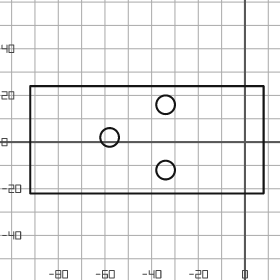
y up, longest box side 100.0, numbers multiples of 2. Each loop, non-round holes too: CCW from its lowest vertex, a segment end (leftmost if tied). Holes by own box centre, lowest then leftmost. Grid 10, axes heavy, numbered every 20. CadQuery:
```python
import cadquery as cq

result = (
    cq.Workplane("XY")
    .moveTo(-92.0, -22.0)
    .lineTo(8.0, -22.0)
    .lineTo(8.0, 24.0)
    .lineTo(-92.0, 24.0)
    .close()
    .moveTo(-34.0, -12.0)
    .circle(4.0)
    .moveTo(-58.0, 2.0)
    .circle(4.0)
    .moveTo(-34.0, 16.0)
    .circle(4.0)
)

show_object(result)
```